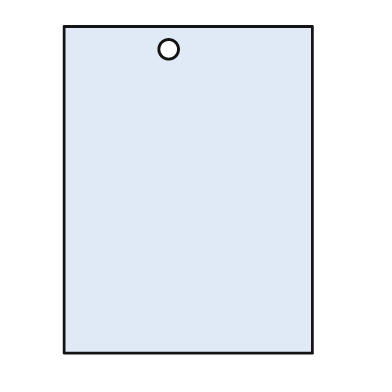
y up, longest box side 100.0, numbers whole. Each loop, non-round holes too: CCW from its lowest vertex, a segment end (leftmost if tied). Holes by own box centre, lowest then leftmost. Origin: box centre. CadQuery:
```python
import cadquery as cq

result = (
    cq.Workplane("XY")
    .moveTo(-38.0, -50.0)
    .lineTo(38.0, -50.0)
    .lineTo(38.0, 50.0)
    .lineTo(-38.0, 50.0)
    .close()
    .moveTo(-6.0, 43.0)
    .circle(3.0)
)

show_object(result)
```